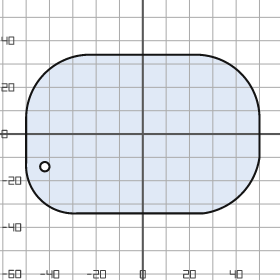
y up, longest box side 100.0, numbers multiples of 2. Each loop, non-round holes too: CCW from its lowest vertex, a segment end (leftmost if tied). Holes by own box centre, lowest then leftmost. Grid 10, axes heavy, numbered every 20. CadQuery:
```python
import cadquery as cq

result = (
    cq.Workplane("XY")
    .moveTo(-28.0, -34.0)
    .lineTo(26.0, -34.0)
    .threePointArc((42.0, -26.0), (50.0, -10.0))
    .lineTo(50.0, 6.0)
    .threePointArc((42.0, 26.0), (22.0, 34.0))
    .lineTo(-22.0, 34.0)
    .threePointArc((-42.0, 26.0), (-50.0, 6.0))
    .lineTo(-50.0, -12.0)
    .threePointArc((-44.0, -28.0), (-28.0, -34.0))
    .close()
    .moveTo(-42.0, -14.0)
    .circle(2.0)
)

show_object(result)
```